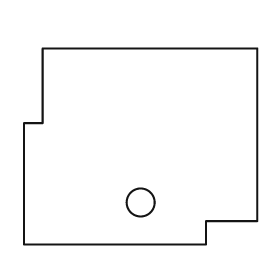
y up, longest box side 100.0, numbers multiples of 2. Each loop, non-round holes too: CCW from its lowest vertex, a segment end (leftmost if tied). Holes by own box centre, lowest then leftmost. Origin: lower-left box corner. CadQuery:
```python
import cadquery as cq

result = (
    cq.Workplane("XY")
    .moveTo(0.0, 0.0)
    .lineTo(78.0, 0.0)
    .lineTo(78.0, 10.0)
    .lineTo(100.0, 10.0)
    .lineTo(100.0, 84.0)
    .lineTo(8.0, 84.0)
    .lineTo(8.0, 52.0)
    .lineTo(0.0, 52.0)
    .close()
    .moveTo(50.0, 18.0)
    .circle(6.0)
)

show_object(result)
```